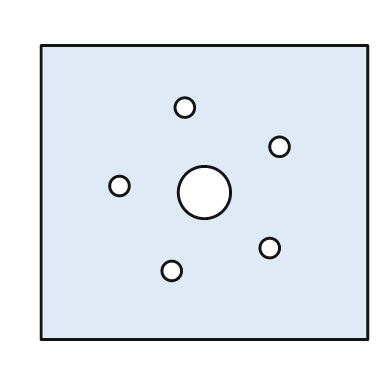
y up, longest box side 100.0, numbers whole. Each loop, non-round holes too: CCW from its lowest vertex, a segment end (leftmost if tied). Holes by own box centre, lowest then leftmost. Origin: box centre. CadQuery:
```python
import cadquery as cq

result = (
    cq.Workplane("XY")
    .moveTo(-50.0, -45.0)
    .lineTo(50.0, -45.0)
    .lineTo(50.0, 45.0)
    .lineTo(-50.0, 45.0)
    .close()
    .moveTo(-10.0, -24.0)
    .circle(3.0)
    .moveTo(20.0, -17.0)
    .circle(3.0)
    .moveTo(0.0, 0.0)
    .circle(8.0)
    .moveTo(-26.0, 2.0)
    .circle(3.0)
    .moveTo(23.0, 14.0)
    .circle(3.0)
    .moveTo(-6.0, 26.0)
    .circle(3.0)
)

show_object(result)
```